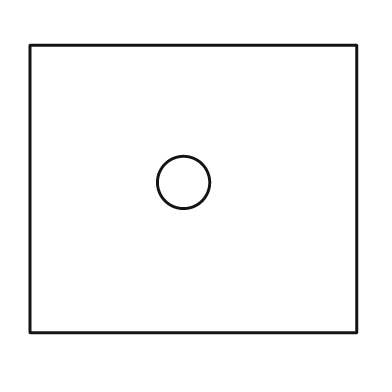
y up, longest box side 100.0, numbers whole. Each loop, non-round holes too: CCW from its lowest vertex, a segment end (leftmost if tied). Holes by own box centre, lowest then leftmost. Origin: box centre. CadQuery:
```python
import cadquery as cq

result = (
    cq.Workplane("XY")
    .moveTo(-50.0, -44.0)
    .lineTo(50.0, -44.0)
    .lineTo(50.0, 44.0)
    .lineTo(-50.0, 44.0)
    .close()
    .moveTo(-3.0, 2.0)
    .circle(8.0)
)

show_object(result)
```